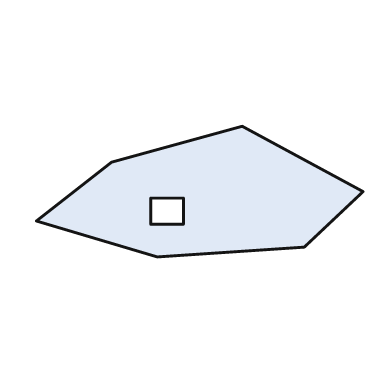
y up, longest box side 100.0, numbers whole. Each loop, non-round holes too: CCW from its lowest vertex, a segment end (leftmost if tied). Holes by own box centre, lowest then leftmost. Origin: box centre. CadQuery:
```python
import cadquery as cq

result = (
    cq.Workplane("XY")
    .moveTo(-13.0, -20.0)
    .lineTo(32.0, -17.0)
    .lineTo(50.0, 0.0)
    .lineTo(13.0, 20.0)
    .lineTo(-27.0, 9.0)
    .lineTo(-50.0, -9.0)
    .close()
    .moveTo(-15.0, -10.0)
    .lineTo(-5.0, -10.0)
    .lineTo(-5.0, -2.0)
    .lineTo(-15.0, -2.0)
    .close()
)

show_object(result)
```